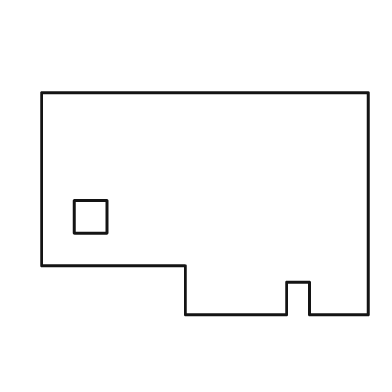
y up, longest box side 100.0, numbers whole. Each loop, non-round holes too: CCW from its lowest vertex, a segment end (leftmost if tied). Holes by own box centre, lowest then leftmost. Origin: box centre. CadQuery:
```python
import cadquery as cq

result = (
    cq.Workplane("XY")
    .moveTo(-6.0, -34.0)
    .lineTo(25.0, -34.0)
    .lineTo(25.0, -24.0)
    .lineTo(32.0, -24.0)
    .lineTo(32.0, -34.0)
    .lineTo(50.0, -34.0)
    .lineTo(50.0, 34.0)
    .lineTo(-50.0, 34.0)
    .lineTo(-50.0, -19.0)
    .lineTo(-6.0, -19.0)
    .close()
    .moveTo(-40.0, -9.0)
    .lineTo(-30.0, -9.0)
    .lineTo(-30.0, 1.0)
    .lineTo(-40.0, 1.0)
    .close()
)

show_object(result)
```